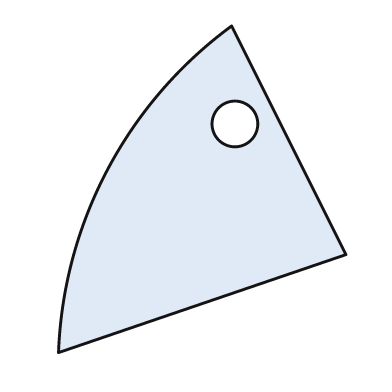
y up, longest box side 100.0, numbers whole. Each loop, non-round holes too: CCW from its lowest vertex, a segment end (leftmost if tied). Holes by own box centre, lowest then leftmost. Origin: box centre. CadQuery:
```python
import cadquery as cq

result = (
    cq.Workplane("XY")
    .moveTo(-44.0, -50.0)
    .lineTo(44.0, -20.0)
    .lineTo(9.0, 50.0)
    .threePointArc((-29.0, 6.0), (-44.0, -50.0))
    .close()
    .moveTo(10.0, 20.0)
    .circle(7.0)
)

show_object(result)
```